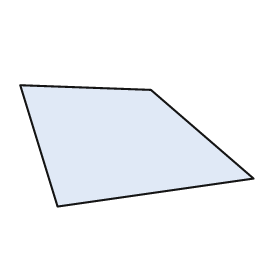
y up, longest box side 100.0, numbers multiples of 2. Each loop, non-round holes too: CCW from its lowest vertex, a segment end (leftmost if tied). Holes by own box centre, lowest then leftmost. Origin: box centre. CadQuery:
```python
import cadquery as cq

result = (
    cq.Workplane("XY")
    .moveTo(-34.0, -26.0)
    .lineTo(50.0, -14.0)
    .lineTo(6.0, 24.0)
    .lineTo(-50.0, 26.0)
    .close()
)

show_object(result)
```